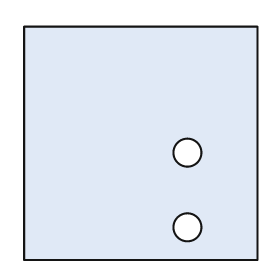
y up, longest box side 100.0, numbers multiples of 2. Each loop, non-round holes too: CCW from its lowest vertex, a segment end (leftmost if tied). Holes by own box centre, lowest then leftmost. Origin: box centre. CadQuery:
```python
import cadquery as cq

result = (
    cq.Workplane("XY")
    .moveTo(-50.0, -50.0)
    .lineTo(50.0, -50.0)
    .lineTo(50.0, 50.0)
    .lineTo(-50.0, 50.0)
    .close()
    .moveTo(20.0, -36.0)
    .circle(6.0)
    .moveTo(20.0, -4.0)
    .circle(6.0)
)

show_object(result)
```